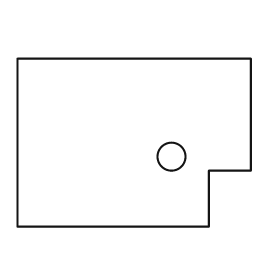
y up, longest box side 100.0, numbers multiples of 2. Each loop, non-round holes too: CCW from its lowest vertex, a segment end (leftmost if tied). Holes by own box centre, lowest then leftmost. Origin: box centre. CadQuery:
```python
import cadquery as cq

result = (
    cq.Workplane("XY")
    .moveTo(-50.0, -36.0)
    .lineTo(32.0, -36.0)
    .lineTo(32.0, -12.0)
    .lineTo(50.0, -12.0)
    .lineTo(50.0, 36.0)
    .lineTo(-50.0, 36.0)
    .close()
    .moveTo(16.0, -6.0)
    .circle(6.0)
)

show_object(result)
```